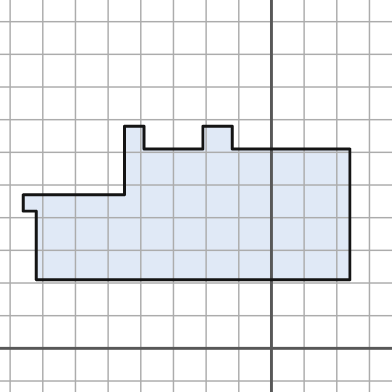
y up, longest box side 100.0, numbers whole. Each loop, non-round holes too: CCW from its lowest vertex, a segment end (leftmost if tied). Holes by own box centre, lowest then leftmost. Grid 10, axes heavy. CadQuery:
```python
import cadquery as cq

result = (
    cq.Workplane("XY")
    .moveTo(-72.0, 21.0)
    .lineTo(24.0, 21.0)
    .lineTo(24.0, 61.0)
    .lineTo(-12.0, 61.0)
    .lineTo(-12.0, 68.0)
    .lineTo(-21.0, 68.0)
    .lineTo(-21.0, 61.0)
    .lineTo(-39.0, 61.0)
    .lineTo(-39.0, 68.0)
    .lineTo(-45.0, 68.0)
    .lineTo(-45.0, 47.0)
    .lineTo(-76.0, 47.0)
    .lineTo(-76.0, 42.0)
    .lineTo(-72.0, 42.0)
    .close()
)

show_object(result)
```